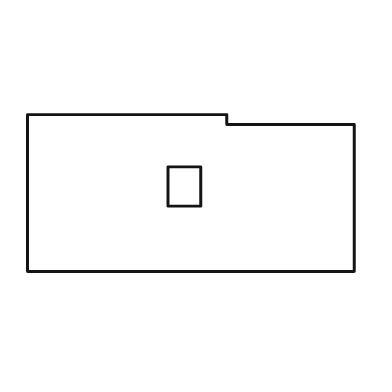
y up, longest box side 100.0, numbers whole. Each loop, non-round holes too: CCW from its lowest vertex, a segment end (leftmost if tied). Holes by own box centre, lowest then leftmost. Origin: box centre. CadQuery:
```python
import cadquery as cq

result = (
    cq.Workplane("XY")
    .moveTo(-50.0, -24.0)
    .lineTo(50.0, -24.0)
    .lineTo(50.0, 21.0)
    .lineTo(11.0, 21.0)
    .lineTo(11.0, 24.0)
    .lineTo(-50.0, 24.0)
    .close()
    .moveTo(-7.0, -4.0)
    .lineTo(3.0, -4.0)
    .lineTo(3.0, 8.0)
    .lineTo(-7.0, 8.0)
    .close()
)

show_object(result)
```